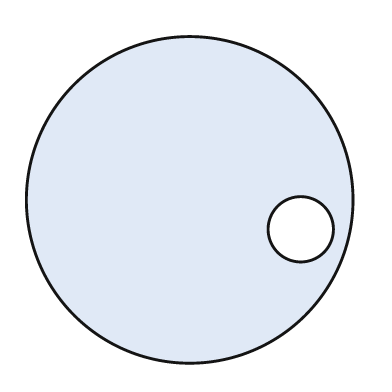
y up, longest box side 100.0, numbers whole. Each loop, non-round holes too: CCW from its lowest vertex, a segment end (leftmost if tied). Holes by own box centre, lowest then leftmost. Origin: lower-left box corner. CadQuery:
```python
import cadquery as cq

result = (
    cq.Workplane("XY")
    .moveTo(50.0, 50.0)
    .circle(50.0)
    .moveTo(84.0, 41.0)
    .circle(10.0)
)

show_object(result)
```